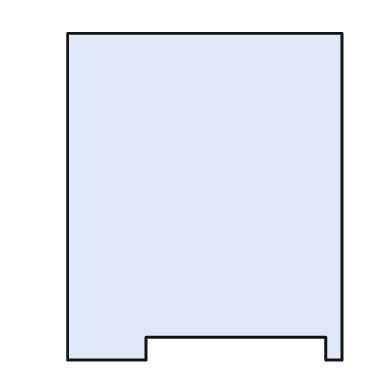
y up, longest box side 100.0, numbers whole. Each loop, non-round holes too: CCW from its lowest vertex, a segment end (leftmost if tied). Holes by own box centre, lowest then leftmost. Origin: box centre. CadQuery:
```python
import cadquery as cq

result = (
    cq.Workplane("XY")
    .moveTo(-42.0, -50.0)
    .lineTo(-18.0, -50.0)
    .lineTo(-18.0, -43.0)
    .lineTo(37.0, -43.0)
    .lineTo(37.0, -50.0)
    .lineTo(42.0, -50.0)
    .lineTo(42.0, 50.0)
    .lineTo(-42.0, 50.0)
    .close()
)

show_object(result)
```